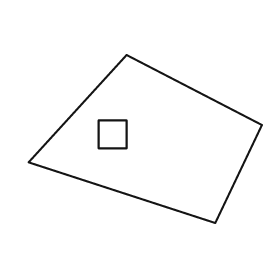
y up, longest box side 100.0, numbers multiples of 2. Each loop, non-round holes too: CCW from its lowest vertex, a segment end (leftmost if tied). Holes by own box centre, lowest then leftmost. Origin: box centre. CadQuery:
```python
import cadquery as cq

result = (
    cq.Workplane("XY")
    .moveTo(30.0, -36.0)
    .lineTo(50.0, 6.0)
    .lineTo(-8.0, 36.0)
    .lineTo(-50.0, -10.0)
    .close()
    .moveTo(-20.0, -4.0)
    .lineTo(-8.0, -4.0)
    .lineTo(-8.0, 8.0)
    .lineTo(-20.0, 8.0)
    .close()
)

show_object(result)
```